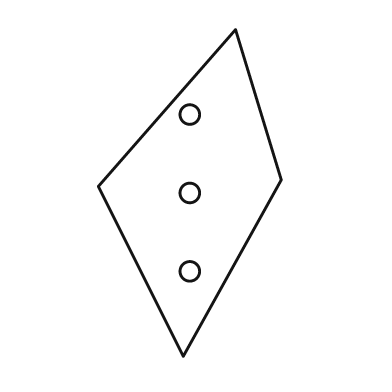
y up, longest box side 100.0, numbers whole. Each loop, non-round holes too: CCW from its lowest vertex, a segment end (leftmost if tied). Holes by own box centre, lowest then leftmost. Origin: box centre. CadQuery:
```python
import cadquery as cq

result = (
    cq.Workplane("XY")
    .moveTo(-2.0, -50.0)
    .lineTo(28.0, 4.0)
    .lineTo(14.0, 50.0)
    .lineTo(-28.0, 2.0)
    .close()
    .moveTo(0.0, -24.0)
    .circle(3.0)
    .moveTo(0.0, 0.0)
    .circle(3.0)
    .moveTo(0.0, 24.0)
    .circle(3.0)
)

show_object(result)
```